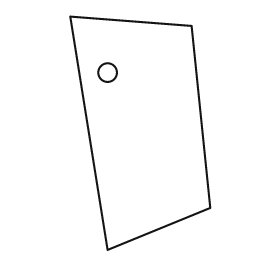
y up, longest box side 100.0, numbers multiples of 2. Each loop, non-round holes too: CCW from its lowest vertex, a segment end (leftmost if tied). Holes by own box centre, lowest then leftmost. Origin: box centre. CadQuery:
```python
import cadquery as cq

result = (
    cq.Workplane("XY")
    .moveTo(-14.0, -50.0)
    .lineTo(30.0, -32.0)
    .lineTo(22.0, 46.0)
    .lineTo(-30.0, 50.0)
    .close()
    .moveTo(-14.0, 26.0)
    .circle(4.0)
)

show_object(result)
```